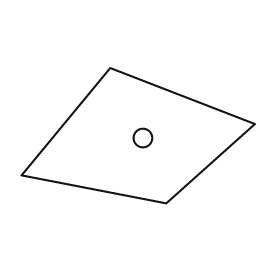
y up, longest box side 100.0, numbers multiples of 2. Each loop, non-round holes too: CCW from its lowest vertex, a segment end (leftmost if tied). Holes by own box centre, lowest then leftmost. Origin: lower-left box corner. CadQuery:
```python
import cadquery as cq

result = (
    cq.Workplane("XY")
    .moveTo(62.0, 0.0)
    .lineTo(100.0, 34.0)
    .lineTo(38.0, 58.0)
    .lineTo(0.0, 12.0)
    .close()
    .moveTo(52.0, 28.0)
    .circle(4.0)
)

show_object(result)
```